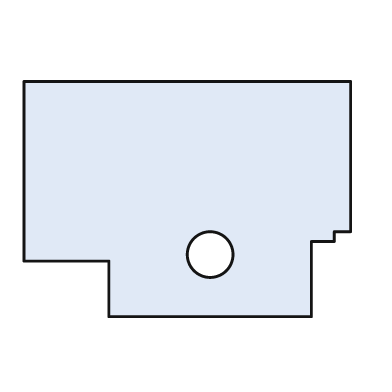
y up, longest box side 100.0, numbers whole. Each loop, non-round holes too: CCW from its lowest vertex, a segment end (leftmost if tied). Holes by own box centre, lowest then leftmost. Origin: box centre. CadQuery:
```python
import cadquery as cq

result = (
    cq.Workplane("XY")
    .moveTo(-24.0, -36.0)
    .lineTo(38.0, -36.0)
    .lineTo(38.0, -13.0)
    .lineTo(45.0, -13.0)
    .lineTo(45.0, -10.0)
    .lineTo(50.0, -10.0)
    .lineTo(50.0, 36.0)
    .lineTo(-50.0, 36.0)
    .lineTo(-50.0, -19.0)
    .lineTo(-24.0, -19.0)
    .close()
    .moveTo(7.0, -17.0)
    .circle(7.0)
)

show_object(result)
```